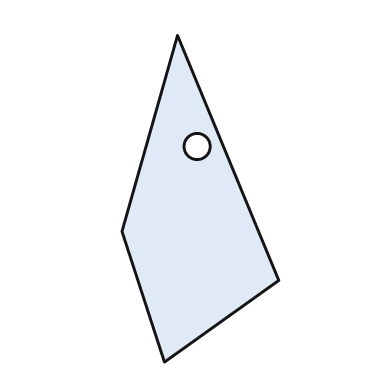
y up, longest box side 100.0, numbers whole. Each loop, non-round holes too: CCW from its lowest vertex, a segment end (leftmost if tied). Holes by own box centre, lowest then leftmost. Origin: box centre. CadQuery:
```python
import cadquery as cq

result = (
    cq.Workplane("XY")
    .moveTo(-11.0, -50.0)
    .lineTo(24.0, -25.0)
    .lineTo(-7.0, 50.0)
    .lineTo(-24.0, -10.0)
    .close()
    .moveTo(-1.0, 16.0)
    .circle(4.0)
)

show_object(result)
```